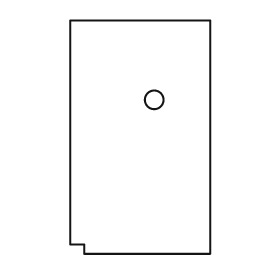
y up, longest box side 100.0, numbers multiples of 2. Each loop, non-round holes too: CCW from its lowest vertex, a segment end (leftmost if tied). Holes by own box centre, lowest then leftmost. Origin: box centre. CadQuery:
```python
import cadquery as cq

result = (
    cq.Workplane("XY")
    .moveTo(-24.0, -50.0)
    .lineTo(30.0, -50.0)
    .lineTo(30.0, 50.0)
    .lineTo(-30.0, 50.0)
    .lineTo(-30.0, -46.0)
    .lineTo(-24.0, -46.0)
    .close()
    .moveTo(6.0, 16.0)
    .circle(4.0)
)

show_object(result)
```